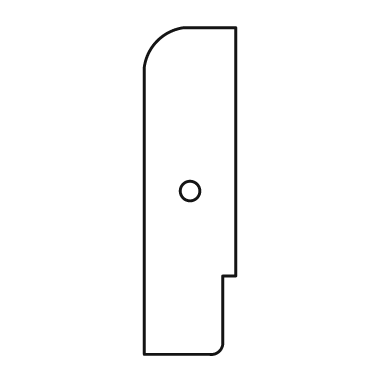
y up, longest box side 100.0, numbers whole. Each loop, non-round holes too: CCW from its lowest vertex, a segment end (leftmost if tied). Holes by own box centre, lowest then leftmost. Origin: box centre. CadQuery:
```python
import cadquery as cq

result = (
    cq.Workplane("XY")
    .moveTo(-14.0, -50.0)
    .lineTo(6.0, -50.0)
    .threePointArc((9.0, -49.0), (10.0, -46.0))
    .lineTo(10.0, -26.0)
    .lineTo(14.0, -26.0)
    .lineTo(14.0, 50.0)
    .lineTo(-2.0, 50.0)
    .threePointArc((-10.0, 46.0), (-14.0, 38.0))
    .close()
    .moveTo(0.0, 0.0)
    .circle(3.0)
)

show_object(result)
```